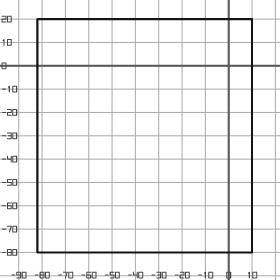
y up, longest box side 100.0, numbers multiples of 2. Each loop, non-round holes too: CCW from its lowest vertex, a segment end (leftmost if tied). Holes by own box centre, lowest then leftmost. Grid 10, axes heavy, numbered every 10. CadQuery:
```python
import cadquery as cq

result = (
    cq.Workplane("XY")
    .moveTo(-82.0, -80.0)
    .lineTo(10.0, -80.0)
    .lineTo(10.0, 20.0)
    .lineTo(-82.0, 20.0)
    .close()
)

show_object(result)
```